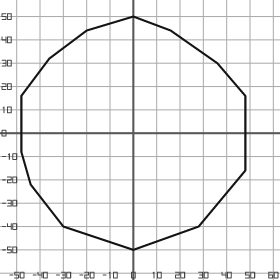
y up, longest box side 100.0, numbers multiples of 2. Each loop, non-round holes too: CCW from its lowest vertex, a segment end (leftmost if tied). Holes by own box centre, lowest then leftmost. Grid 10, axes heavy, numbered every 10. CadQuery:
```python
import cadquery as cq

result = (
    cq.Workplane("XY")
    .moveTo(0.0, -50.0)
    .lineTo(28.0, -40.0)
    .lineTo(48.0, -16.0)
    .lineTo(48.0, 16.0)
    .lineTo(36.0, 30.0)
    .lineTo(16.0, 44.0)
    .lineTo(0.0, 50.0)
    .lineTo(-20.0, 44.0)
    .lineTo(-36.0, 32.0)
    .lineTo(-48.0, 16.0)
    .lineTo(-48.0, -8.0)
    .lineTo(-44.0, -22.0)
    .lineTo(-30.0, -40.0)
    .close()
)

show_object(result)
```